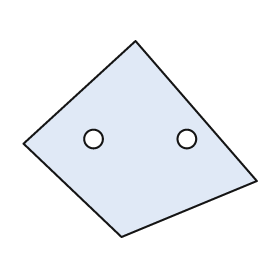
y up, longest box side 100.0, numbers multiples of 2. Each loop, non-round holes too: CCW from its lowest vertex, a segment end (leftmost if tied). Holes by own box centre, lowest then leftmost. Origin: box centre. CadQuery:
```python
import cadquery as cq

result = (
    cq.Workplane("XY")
    .moveTo(-8.0, -42.0)
    .lineTo(50.0, -18.0)
    .lineTo(-2.0, 42.0)
    .lineTo(-50.0, -2.0)
    .close()
    .moveTo(-20.0, 0.0)
    .circle(4.0)
    .moveTo(20.0, 0.0)
    .circle(4.0)
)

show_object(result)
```